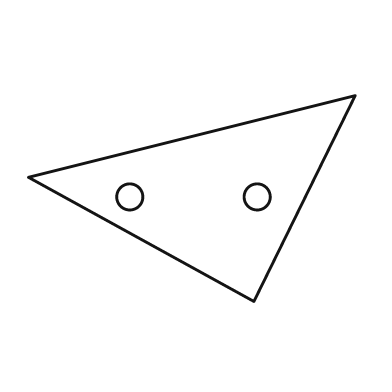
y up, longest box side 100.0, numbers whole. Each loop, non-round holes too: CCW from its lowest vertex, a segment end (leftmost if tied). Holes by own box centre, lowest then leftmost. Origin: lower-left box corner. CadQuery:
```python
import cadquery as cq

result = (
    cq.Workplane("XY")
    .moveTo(69.0, 0.0)
    .lineTo(100.0, 63.0)
    .lineTo(0.0, 38.0)
    .close()
    .moveTo(31.0, 32.0)
    .circle(4.0)
    .moveTo(70.0, 32.0)
    .circle(4.0)
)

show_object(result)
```